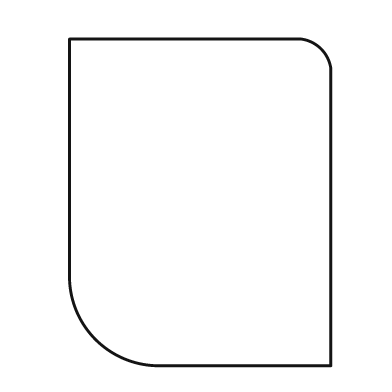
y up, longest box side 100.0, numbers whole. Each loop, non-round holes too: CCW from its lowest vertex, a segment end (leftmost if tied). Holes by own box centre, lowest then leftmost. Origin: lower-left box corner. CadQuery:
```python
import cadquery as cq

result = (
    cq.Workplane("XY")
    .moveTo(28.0, 0.0)
    .lineTo(80.0, 0.0)
    .lineTo(80.0, 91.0)
    .threePointArc((77.0, 97.0), (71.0, 100.0))
    .lineTo(0.0, 100.0)
    .lineTo(0.0, 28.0)
    .threePointArc((8.0, 8.0), (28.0, 0.0))
    .close()
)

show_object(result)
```